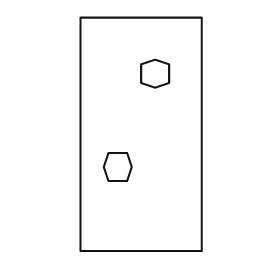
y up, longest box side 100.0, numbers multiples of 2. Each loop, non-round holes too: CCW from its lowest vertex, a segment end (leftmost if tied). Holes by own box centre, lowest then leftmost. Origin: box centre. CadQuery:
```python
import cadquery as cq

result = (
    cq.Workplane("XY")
    .moveTo(-26.0, -50.0)
    .lineTo(26.0, -50.0)
    .lineTo(26.0, 50.0)
    .lineTo(-26.0, 50.0)
    .close()
    .moveTo(-14.0, -20.0)
    .lineTo(-6.0, -20.0)
    .lineTo(-4.0, -14.0)
    .lineTo(-6.0, -8.0)
    .lineTo(-14.0, -8.0)
    .lineTo(-16.0, -14.0)
    .close()
    .moveTo(6.0, 20.0)
    .lineTo(12.0, 22.0)
    .lineTo(12.0, 30.0)
    .lineTo(6.0, 32.0)
    .lineTo(0.0, 30.0)
    .lineTo(0.0, 22.0)
    .close()
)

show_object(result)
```